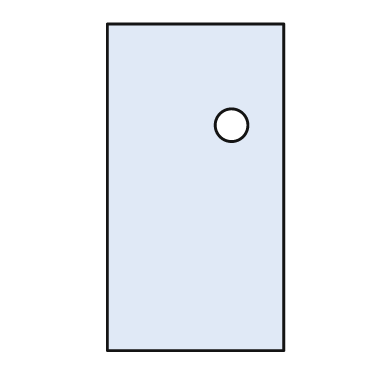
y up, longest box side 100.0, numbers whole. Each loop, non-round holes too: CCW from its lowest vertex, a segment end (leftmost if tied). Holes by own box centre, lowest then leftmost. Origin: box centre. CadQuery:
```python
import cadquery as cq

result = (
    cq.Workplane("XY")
    .moveTo(-27.0, -50.0)
    .lineTo(27.0, -50.0)
    .lineTo(27.0, 50.0)
    .lineTo(-27.0, 50.0)
    .close()
    .moveTo(11.0, 19.0)
    .circle(5.0)
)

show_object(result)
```